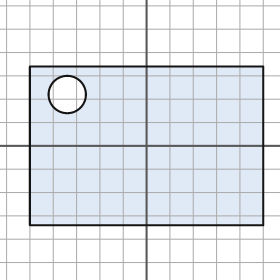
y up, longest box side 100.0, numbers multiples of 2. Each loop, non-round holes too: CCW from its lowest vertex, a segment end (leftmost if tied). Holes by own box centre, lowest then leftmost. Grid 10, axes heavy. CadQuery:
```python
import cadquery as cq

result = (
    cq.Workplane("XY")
    .moveTo(-50.0, -34.0)
    .lineTo(50.0, -34.0)
    .lineTo(50.0, 34.0)
    .lineTo(-50.0, 34.0)
    .close()
    .moveTo(-34.0, 22.0)
    .circle(8.0)
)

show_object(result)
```